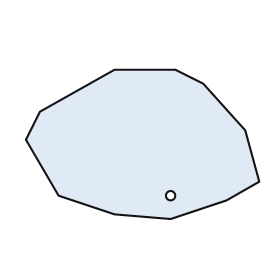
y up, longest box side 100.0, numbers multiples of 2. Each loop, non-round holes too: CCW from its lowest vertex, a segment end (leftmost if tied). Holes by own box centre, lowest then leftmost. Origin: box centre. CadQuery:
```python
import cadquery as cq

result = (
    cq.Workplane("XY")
    .moveTo(12.0, -32.0)
    .lineTo(36.0, -24.0)
    .lineTo(50.0, -16.0)
    .lineTo(44.0, 6.0)
    .lineTo(26.0, 26.0)
    .lineTo(14.0, 32.0)
    .lineTo(-12.0, 32.0)
    .lineTo(-44.0, 14.0)
    .lineTo(-50.0, 2.0)
    .lineTo(-36.0, -22.0)
    .lineTo(-12.0, -30.0)
    .close()
    .moveTo(12.0, -22.0)
    .circle(2.0)
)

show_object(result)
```